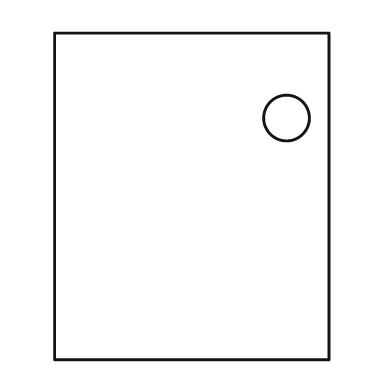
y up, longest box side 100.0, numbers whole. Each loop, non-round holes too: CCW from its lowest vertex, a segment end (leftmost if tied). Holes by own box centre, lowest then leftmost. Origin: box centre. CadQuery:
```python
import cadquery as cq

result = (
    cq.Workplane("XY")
    .moveTo(-42.0, -50.0)
    .lineTo(42.0, -50.0)
    .lineTo(42.0, 50.0)
    .lineTo(-42.0, 50.0)
    .close()
    .moveTo(29.0, 24.0)
    .circle(7.0)
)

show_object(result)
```